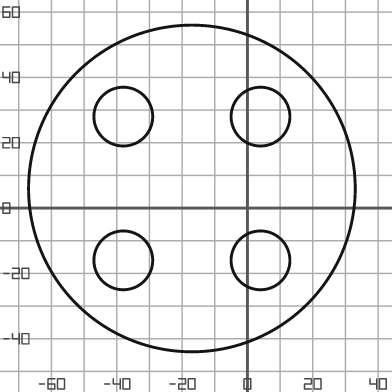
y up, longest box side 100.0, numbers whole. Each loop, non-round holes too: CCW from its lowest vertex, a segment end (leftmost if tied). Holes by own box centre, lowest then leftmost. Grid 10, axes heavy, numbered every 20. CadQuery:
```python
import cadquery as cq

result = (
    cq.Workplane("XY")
    .moveTo(-17.0, 6.0)
    .circle(50.0)
    .moveTo(-38.0, -16.0)
    .circle(9.0)
    .moveTo(4.0, -16.0)
    .circle(9.0)
    .moveTo(-38.0, 28.0)
    .circle(9.0)
    .moveTo(4.0, 28.0)
    .circle(9.0)
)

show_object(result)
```